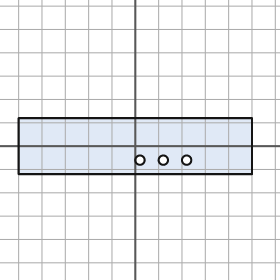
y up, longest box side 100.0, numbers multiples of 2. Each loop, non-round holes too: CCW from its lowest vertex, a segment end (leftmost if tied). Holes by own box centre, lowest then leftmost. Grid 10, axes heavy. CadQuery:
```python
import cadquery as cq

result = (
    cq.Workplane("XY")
    .moveTo(-50.0, -12.0)
    .lineTo(50.0, -12.0)
    .lineTo(50.0, 12.0)
    .lineTo(-50.0, 12.0)
    .close()
    .moveTo(2.0, -6.0)
    .circle(2.0)
    .moveTo(12.0, -6.0)
    .circle(2.0)
    .moveTo(22.0, -6.0)
    .circle(2.0)
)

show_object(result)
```